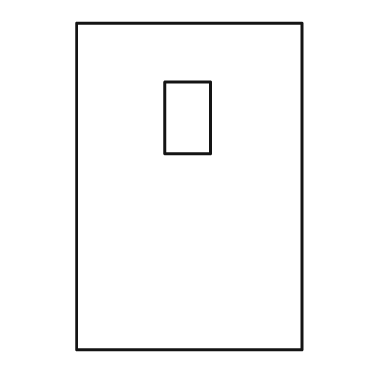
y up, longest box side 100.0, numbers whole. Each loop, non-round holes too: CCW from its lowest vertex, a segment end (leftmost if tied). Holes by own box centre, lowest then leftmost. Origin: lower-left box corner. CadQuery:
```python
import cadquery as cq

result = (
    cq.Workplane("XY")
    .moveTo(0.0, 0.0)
    .lineTo(69.0, 0.0)
    .lineTo(69.0, 100.0)
    .lineTo(0.0, 100.0)
    .close()
    .moveTo(27.0, 60.0)
    .lineTo(41.0, 60.0)
    .lineTo(41.0, 82.0)
    .lineTo(27.0, 82.0)
    .close()
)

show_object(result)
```